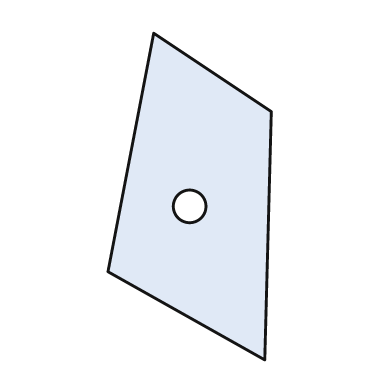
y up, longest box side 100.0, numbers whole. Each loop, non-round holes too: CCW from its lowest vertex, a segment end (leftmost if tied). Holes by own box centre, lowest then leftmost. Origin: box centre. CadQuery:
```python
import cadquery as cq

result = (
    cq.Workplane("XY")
    .moveTo(23.0, -50.0)
    .lineTo(25.0, 26.0)
    .lineTo(-11.0, 50.0)
    .lineTo(-25.0, -23.0)
    .close()
    .moveTo(0.0, -3.0)
    .circle(5.0)
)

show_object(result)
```